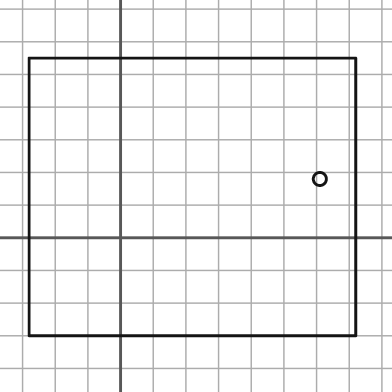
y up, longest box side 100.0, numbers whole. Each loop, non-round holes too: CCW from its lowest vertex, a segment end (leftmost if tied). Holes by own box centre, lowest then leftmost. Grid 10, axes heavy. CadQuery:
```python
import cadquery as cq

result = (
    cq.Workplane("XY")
    .moveTo(-28.0, -30.0)
    .lineTo(72.0, -30.0)
    .lineTo(72.0, 55.0)
    .lineTo(-28.0, 55.0)
    .close()
    .moveTo(61.0, 18.0)
    .circle(2.0)
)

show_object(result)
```